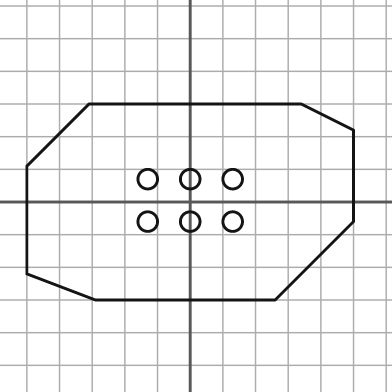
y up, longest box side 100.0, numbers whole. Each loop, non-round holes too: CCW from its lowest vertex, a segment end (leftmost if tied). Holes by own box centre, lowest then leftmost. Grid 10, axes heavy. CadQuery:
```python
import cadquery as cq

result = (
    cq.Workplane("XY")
    .moveTo(-29.0, -30.0)
    .lineTo(26.0, -30.0)
    .lineTo(50.0, -6.0)
    .lineTo(50.0, 22.0)
    .lineTo(34.0, 30.0)
    .lineTo(-31.0, 30.0)
    .lineTo(-50.0, 11.0)
    .lineTo(-50.0, -22.0)
    .close()
    .moveTo(-13.0, -6.0)
    .circle(3.0)
    .moveTo(0.0, -6.0)
    .circle(3.0)
    .moveTo(13.0, -6.0)
    .circle(3.0)
    .moveTo(-13.0, 7.0)
    .circle(3.0)
    .moveTo(0.0, 7.0)
    .circle(3.0)
    .moveTo(13.0, 7.0)
    .circle(3.0)
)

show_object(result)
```